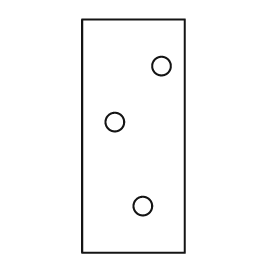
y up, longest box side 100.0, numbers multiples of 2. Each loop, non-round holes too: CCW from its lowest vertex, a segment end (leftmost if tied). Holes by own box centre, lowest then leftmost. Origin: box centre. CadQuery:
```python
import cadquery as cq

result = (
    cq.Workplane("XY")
    .moveTo(-22.0, -50.0)
    .lineTo(22.0, -50.0)
    .lineTo(22.0, 50.0)
    .lineTo(-22.0, 50.0)
    .close()
    .moveTo(4.0, -30.0)
    .circle(4.0)
    .moveTo(-8.0, 6.0)
    .circle(4.0)
    .moveTo(12.0, 30.0)
    .circle(4.0)
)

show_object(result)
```